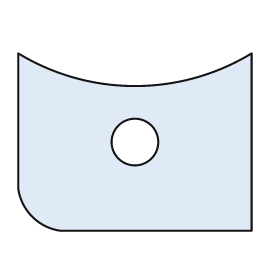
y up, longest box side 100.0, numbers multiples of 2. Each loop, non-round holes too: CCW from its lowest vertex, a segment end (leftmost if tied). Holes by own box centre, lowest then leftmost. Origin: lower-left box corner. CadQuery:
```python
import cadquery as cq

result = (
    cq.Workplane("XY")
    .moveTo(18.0, 0.0)
    .lineTo(100.0, 0.0)
    .lineTo(100.0, 76.0)
    .threePointArc((50.0, 62.0), (0.0, 76.0))
    .lineTo(0.0, 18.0)
    .threePointArc((6.0, 6.0), (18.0, 0.0))
    .close()
    .moveTo(50.0, 38.0)
    .circle(10.0)
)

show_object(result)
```